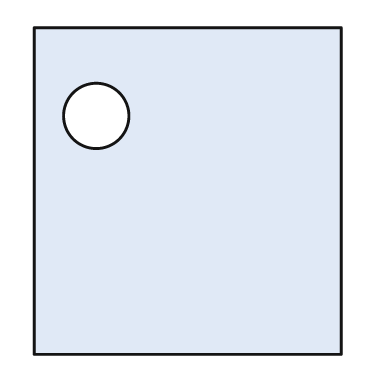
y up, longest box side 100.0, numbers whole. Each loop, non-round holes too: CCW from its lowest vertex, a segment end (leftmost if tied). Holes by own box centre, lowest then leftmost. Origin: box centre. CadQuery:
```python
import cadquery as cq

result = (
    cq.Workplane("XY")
    .moveTo(-47.0, -50.0)
    .lineTo(47.0, -50.0)
    .lineTo(47.0, 50.0)
    .lineTo(-47.0, 50.0)
    .close()
    .moveTo(-28.0, 23.0)
    .circle(10.0)
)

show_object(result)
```